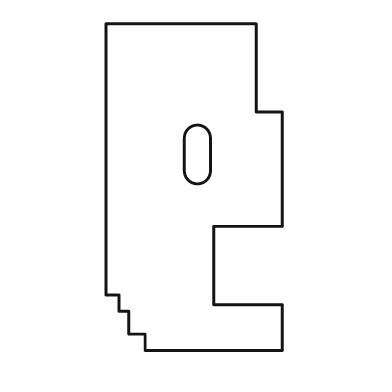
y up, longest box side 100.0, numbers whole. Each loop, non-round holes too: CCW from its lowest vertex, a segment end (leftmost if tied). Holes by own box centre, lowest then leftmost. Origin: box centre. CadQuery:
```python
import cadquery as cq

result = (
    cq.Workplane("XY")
    .moveTo(-15.0, -50.0)
    .lineTo(27.0, -50.0)
    .lineTo(27.0, -36.0)
    .lineTo(6.0, -36.0)
    .lineTo(6.0, -12.0)
    .lineTo(27.0, -12.0)
    .lineTo(27.0, 23.0)
    .lineTo(19.0, 23.0)
    .lineTo(19.0, 50.0)
    .lineTo(-27.0, 50.0)
    .lineTo(-27.0, -33.0)
    .lineTo(-23.0, -33.0)
    .lineTo(-23.0, -38.0)
    .lineTo(-20.0, -38.0)
    .lineTo(-20.0, -45.0)
    .lineTo(-15.0, -45.0)
    .close()
    .moveTo(-3.0, 5.0)
    .threePointArc((1.0, 1.0), (5.0, 5.0))
    .lineTo(5.0, 15.0)
    .threePointArc((1.0, 19.0), (-3.0, 15.0))
    .close()
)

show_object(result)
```